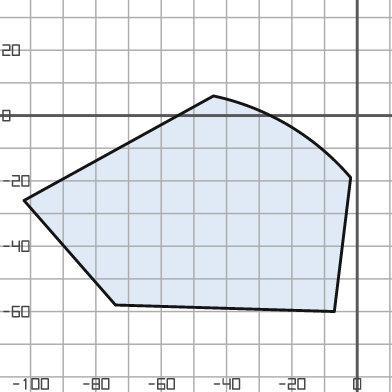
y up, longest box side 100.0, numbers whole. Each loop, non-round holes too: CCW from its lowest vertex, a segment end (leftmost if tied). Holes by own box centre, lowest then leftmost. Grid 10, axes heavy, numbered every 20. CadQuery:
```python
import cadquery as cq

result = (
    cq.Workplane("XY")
    .moveTo(-7.0, -60.0)
    .lineTo(-2.0, -19.0)
    .threePointArc((-21.0, -3.0), (-44.0, 6.0))
    .lineTo(-102.0, -26.0)
    .lineTo(-74.0, -58.0)
    .close()
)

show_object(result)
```